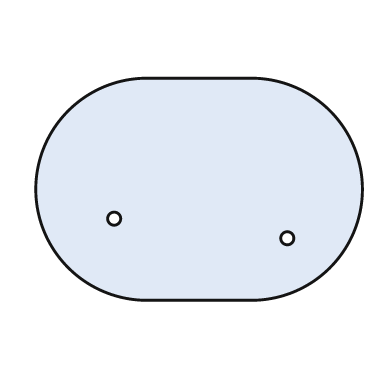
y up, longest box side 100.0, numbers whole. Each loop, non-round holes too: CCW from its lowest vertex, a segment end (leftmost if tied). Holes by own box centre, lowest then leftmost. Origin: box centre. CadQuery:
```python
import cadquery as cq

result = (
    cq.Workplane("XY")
    .moveTo(-16.0, -34.0)
    .lineTo(16.0, -34.0)
    .threePointArc((50.0, 0.0), (16.0, 34.0))
    .lineTo(-16.0, 34.0)
    .threePointArc((-50.0, 0.0), (-16.0, -34.0))
    .close()
    .moveTo(27.0, -15.0)
    .circle(2.0)
    .moveTo(-26.0, -9.0)
    .circle(2.0)
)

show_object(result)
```